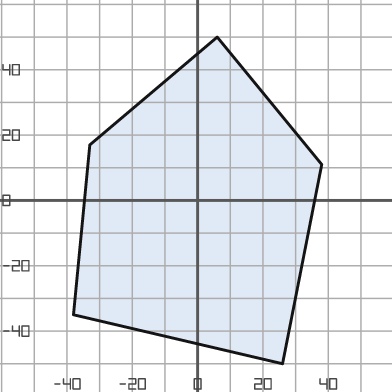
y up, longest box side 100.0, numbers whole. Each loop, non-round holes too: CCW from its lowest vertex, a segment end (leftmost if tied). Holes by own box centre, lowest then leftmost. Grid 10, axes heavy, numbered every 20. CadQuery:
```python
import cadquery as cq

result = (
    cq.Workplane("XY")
    .moveTo(26.0, -50.0)
    .lineTo(38.0, 11.0)
    .lineTo(6.0, 50.0)
    .lineTo(-33.0, 17.0)
    .lineTo(-38.0, -35.0)
    .close()
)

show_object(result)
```